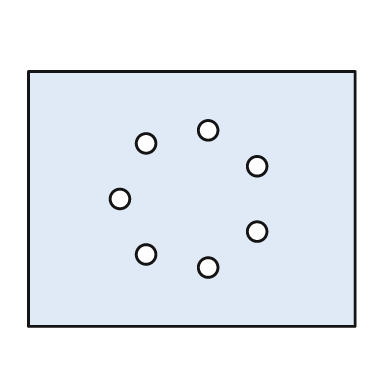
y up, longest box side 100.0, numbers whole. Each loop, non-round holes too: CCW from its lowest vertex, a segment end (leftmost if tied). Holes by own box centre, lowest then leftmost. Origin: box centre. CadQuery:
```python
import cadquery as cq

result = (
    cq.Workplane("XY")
    .moveTo(-50.0, -39.0)
    .lineTo(50.0, -39.0)
    .lineTo(50.0, 39.0)
    .lineTo(-50.0, 39.0)
    .close()
    .moveTo(5.0, -21.0)
    .circle(3.0)
    .moveTo(-14.0, -17.0)
    .circle(3.0)
    .moveTo(20.0, -10.0)
    .circle(3.0)
    .moveTo(-22.0, 0.0)
    .circle(3.0)
    .moveTo(20.0, 10.0)
    .circle(3.0)
    .moveTo(-14.0, 17.0)
    .circle(3.0)
    .moveTo(5.0, 21.0)
    .circle(3.0)
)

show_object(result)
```